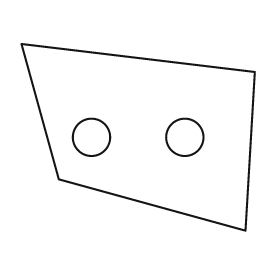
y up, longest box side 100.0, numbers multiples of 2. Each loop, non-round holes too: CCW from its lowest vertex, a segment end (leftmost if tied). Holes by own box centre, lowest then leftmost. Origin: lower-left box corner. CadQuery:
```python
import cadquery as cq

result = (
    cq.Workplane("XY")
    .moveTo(96.0, 0.0)
    .lineTo(100.0, 68.0)
    .lineTo(0.0, 80.0)
    .lineTo(16.0, 22.0)
    .close()
    .moveTo(30.0, 40.0)
    .circle(8.0)
    .moveTo(70.0, 40.0)
    .circle(8.0)
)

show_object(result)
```